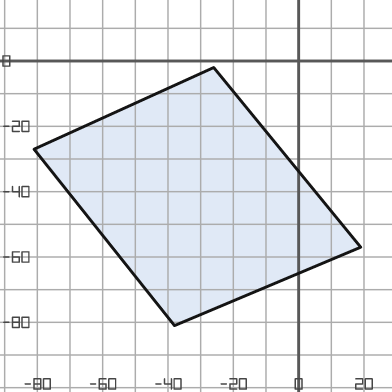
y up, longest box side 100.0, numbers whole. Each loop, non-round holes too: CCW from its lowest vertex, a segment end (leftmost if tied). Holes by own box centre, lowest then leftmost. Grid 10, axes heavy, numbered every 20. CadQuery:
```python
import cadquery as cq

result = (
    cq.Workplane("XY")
    .moveTo(-38.0, -81.0)
    .lineTo(19.0, -57.0)
    .lineTo(-26.0, -2.0)
    .lineTo(-81.0, -27.0)
    .close()
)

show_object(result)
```